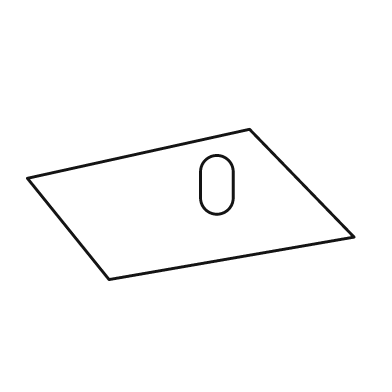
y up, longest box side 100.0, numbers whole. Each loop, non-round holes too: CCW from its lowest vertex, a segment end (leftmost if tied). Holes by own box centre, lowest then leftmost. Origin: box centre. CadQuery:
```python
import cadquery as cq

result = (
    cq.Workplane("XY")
    .moveTo(-25.0, -23.0)
    .lineTo(50.0, -10.0)
    .lineTo(18.0, 23.0)
    .lineTo(-50.0, 8.0)
    .close()
    .moveTo(3.0, 2.0)
    .threePointArc((8.0, -3.0), (13.0, 2.0))
    .lineTo(13.0, 10.0)
    .threePointArc((8.0, 15.0), (3.0, 10.0))
    .close()
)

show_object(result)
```